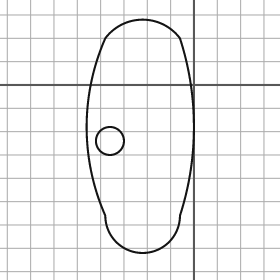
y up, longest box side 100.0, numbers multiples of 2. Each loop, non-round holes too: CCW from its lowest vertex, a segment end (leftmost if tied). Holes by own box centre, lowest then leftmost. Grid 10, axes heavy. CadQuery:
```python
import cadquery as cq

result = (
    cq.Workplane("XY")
    .moveTo(-38.0, -56.0)
    .threePointArc((-22.0, -72.0), (-6.0, -56.0))
    .threePointArc((0.0, -18.0), (-6.0, 20.0))
    .threePointArc((-22.0, 28.0), (-38.0, 20.0))
    .threePointArc((-46.0, -18.0), (-38.0, -56.0))
    .close()
    .moveTo(-36.0, -24.0)
    .circle(6.0)
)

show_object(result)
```